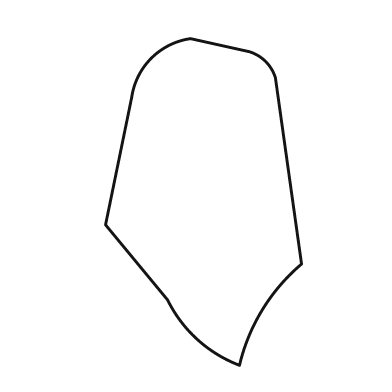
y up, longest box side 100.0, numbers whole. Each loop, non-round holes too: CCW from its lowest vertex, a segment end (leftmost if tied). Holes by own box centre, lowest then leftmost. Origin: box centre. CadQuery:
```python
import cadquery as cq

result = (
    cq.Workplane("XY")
    .moveTo(11.0, -50.0)
    .threePointArc((18.0, -33.0), (30.0, -19.0))
    .lineTo(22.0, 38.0)
    .threePointArc((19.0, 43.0), (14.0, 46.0))
    .lineTo(-4.0, 50.0)
    .threePointArc((-16.0, 44.0), (-22.0, 32.0))
    .lineTo(-30.0, -7.0)
    .lineTo(-11.0, -30.0)
    .threePointArc((-2.0, -42.0), (11.0, -50.0))
    .close()
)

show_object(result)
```